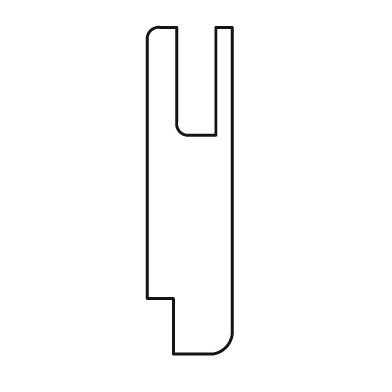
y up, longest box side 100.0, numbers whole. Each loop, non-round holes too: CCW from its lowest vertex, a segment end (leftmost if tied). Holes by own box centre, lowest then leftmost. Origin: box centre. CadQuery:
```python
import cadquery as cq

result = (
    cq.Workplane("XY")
    .moveTo(-5.0, -50.0)
    .lineTo(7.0, -50.0)
    .threePointArc((11.0, -48.0), (13.0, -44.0))
    .lineTo(13.0, 50.0)
    .lineTo(8.0, 50.0)
    .lineTo(8.0, 17.0)
    .lineTo(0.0, 17.0)
    .threePointArc((-3.0, 18.0), (-4.0, 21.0))
    .lineTo(-4.0, 50.0)
    .lineTo(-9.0, 50.0)
    .threePointArc((-12.0, 49.0), (-13.0, 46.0))
    .lineTo(-13.0, -33.0)
    .lineTo(-5.0, -33.0)
    .close()
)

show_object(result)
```